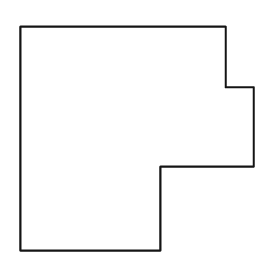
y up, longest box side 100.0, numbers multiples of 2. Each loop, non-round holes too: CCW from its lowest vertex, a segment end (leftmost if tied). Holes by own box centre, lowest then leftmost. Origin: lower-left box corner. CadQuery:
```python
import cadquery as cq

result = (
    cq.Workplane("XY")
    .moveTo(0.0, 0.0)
    .lineTo(60.0, 0.0)
    .lineTo(60.0, 36.0)
    .lineTo(100.0, 36.0)
    .lineTo(100.0, 70.0)
    .lineTo(88.0, 70.0)
    .lineTo(88.0, 96.0)
    .lineTo(0.0, 96.0)
    .close()
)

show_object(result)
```